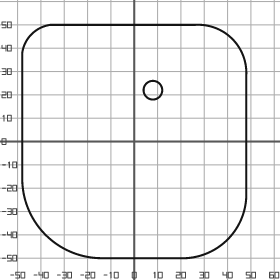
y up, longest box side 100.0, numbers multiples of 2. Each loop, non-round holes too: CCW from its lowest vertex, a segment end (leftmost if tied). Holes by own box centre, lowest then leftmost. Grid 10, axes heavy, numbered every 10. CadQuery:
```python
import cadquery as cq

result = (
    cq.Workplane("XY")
    .moveTo(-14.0, -50.0)
    .lineTo(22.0, -50.0)
    .threePointArc((40.0, -42.0), (48.0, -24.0))
    .lineTo(48.0, 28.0)
    .threePointArc((42.0, 44.0), (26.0, 50.0))
    .lineTo(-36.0, 50.0)
    .threePointArc((-44.0, 46.0), (-48.0, 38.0))
    .lineTo(-48.0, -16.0)
    .threePointArc((-38.0, -40.0), (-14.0, -50.0))
    .close()
    .moveTo(8.0, 22.0)
    .circle(4.0)
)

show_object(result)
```